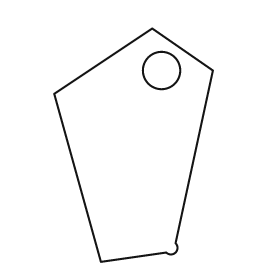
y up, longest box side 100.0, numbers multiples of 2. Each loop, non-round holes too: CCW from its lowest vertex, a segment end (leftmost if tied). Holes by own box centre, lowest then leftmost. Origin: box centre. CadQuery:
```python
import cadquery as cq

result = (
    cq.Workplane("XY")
    .moveTo(-14.0, -50.0)
    .lineTo(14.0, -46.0)
    .threePointArc((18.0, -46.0), (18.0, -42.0))
    .lineTo(34.0, 32.0)
    .lineTo(8.0, 50.0)
    .lineTo(-34.0, 22.0)
    .close()
    .moveTo(12.0, 32.0)
    .circle(8.0)
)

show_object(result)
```